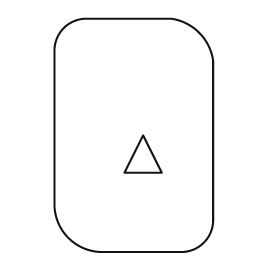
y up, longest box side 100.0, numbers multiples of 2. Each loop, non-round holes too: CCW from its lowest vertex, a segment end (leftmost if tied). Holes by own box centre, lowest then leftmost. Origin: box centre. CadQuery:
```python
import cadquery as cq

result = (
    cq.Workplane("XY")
    .moveTo(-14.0, -50.0)
    .lineTo(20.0, -50.0)
    .threePointArc((30.0, -46.0), (34.0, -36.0))
    .lineTo(34.0, 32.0)
    .threePointArc((28.0, 44.0), (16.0, 50.0))
    .lineTo(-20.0, 50.0)
    .threePointArc((-30.0, 46.0), (-34.0, 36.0))
    .lineTo(-34.0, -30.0)
    .threePointArc((-28.0, -44.0), (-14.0, -50.0))
    .close()
    .moveTo(-4.0, -16.0)
    .lineTo(12.0, -16.0)
    .lineTo(4.0, 0.0)
    .close()
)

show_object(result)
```